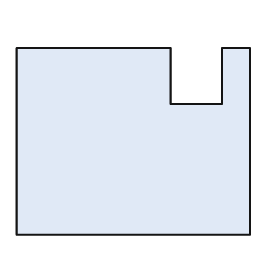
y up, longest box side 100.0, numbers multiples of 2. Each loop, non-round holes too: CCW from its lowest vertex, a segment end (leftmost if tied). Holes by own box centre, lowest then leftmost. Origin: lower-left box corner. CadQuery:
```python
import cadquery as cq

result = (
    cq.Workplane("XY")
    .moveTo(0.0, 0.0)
    .lineTo(100.0, 0.0)
    .lineTo(100.0, 80.0)
    .lineTo(88.0, 80.0)
    .lineTo(88.0, 56.0)
    .lineTo(66.0, 56.0)
    .lineTo(66.0, 80.0)
    .lineTo(0.0, 80.0)
    .close()
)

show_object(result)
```